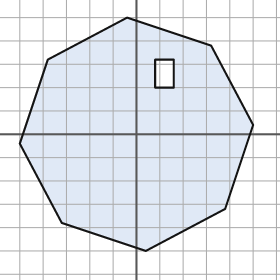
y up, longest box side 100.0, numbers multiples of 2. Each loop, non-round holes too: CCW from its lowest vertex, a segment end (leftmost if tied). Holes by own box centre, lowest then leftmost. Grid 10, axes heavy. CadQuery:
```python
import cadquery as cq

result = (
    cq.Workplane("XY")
    .moveTo(4.0, -50.0)
    .lineTo(38.0, -32.0)
    .lineTo(50.0, 4.0)
    .lineTo(32.0, 38.0)
    .lineTo(-4.0, 50.0)
    .lineTo(-38.0, 32.0)
    .lineTo(-50.0, -4.0)
    .lineTo(-32.0, -38.0)
    .close()
    .moveTo(8.0, 20.0)
    .lineTo(16.0, 20.0)
    .lineTo(16.0, 32.0)
    .lineTo(8.0, 32.0)
    .close()
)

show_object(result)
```